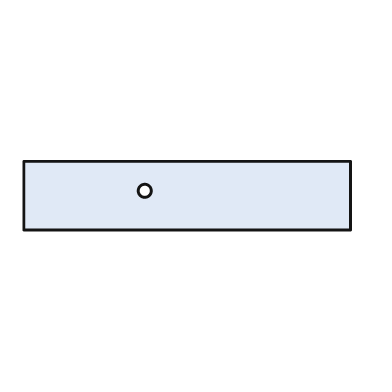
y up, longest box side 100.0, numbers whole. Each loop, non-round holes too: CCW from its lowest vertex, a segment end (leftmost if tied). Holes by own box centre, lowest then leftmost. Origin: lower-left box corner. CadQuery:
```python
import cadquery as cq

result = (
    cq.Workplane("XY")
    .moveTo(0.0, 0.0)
    .lineTo(100.0, 0.0)
    .lineTo(100.0, 21.0)
    .lineTo(0.0, 21.0)
    .close()
    .moveTo(37.0, 12.0)
    .circle(2.0)
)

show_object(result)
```